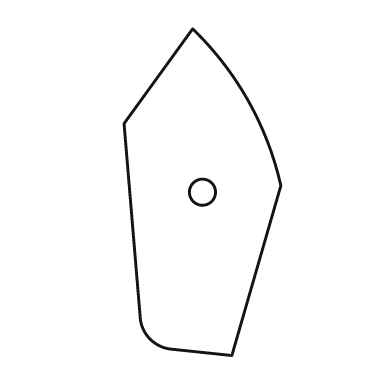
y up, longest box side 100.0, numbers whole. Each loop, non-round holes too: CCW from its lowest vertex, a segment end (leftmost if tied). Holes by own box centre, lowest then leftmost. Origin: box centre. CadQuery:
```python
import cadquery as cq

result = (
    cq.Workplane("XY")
    .moveTo(9.0, -50.0)
    .lineTo(24.0, 2.0)
    .threePointArc((14.0, 28.0), (-3.0, 50.0))
    .lineTo(-24.0, 21.0)
    .lineTo(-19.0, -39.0)
    .threePointArc((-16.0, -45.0), (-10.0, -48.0))
    .close()
    .moveTo(0.0, 0.0)
    .circle(4.0)
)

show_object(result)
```